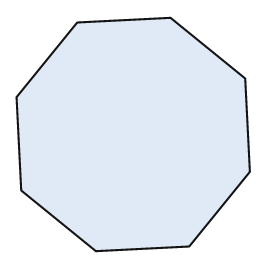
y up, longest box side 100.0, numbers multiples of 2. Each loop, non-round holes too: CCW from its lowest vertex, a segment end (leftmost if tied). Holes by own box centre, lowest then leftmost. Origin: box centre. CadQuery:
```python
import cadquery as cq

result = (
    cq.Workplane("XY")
    .moveTo(-16.0, -50.0)
    .lineTo(24.0, -48.0)
    .lineTo(50.0, -16.0)
    .lineTo(48.0, 24.0)
    .lineTo(16.0, 50.0)
    .lineTo(-24.0, 48.0)
    .lineTo(-50.0, 16.0)
    .lineTo(-48.0, -24.0)
    .close()
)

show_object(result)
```